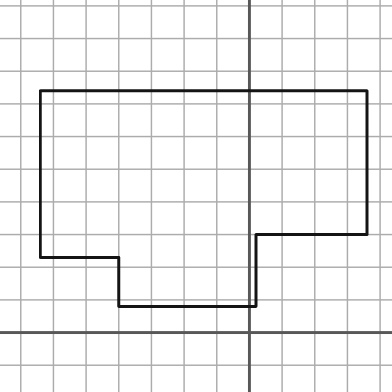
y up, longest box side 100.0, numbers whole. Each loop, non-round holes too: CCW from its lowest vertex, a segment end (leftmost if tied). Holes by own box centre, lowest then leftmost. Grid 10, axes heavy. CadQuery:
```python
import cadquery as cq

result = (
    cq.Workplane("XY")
    .moveTo(-40.0, 8.0)
    .lineTo(2.0, 8.0)
    .lineTo(2.0, 30.0)
    .lineTo(36.0, 30.0)
    .lineTo(36.0, 74.0)
    .lineTo(-64.0, 74.0)
    .lineTo(-64.0, 23.0)
    .lineTo(-40.0, 23.0)
    .close()
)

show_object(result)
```